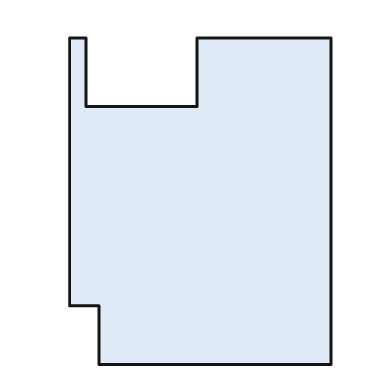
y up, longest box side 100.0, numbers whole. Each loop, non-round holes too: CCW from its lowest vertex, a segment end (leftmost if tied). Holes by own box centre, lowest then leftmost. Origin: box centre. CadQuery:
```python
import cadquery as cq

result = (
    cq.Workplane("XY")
    .moveTo(-31.0, -50.0)
    .lineTo(40.0, -50.0)
    .lineTo(40.0, 50.0)
    .lineTo(-1.0, 50.0)
    .lineTo(-1.0, 29.0)
    .lineTo(-35.0, 29.0)
    .lineTo(-35.0, 50.0)
    .lineTo(-40.0, 50.0)
    .lineTo(-40.0, -32.0)
    .lineTo(-31.0, -32.0)
    .close()
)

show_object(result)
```